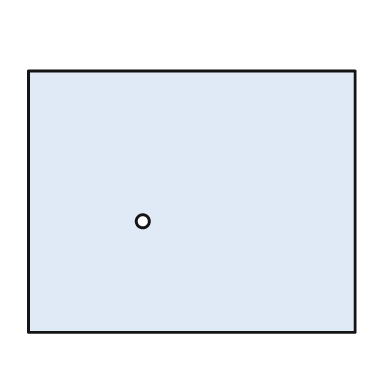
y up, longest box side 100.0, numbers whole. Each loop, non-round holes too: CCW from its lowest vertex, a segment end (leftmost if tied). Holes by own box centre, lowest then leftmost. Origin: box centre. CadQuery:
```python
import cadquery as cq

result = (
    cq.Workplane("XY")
    .moveTo(-50.0, -40.0)
    .lineTo(50.0, -40.0)
    .lineTo(50.0, 40.0)
    .lineTo(-50.0, 40.0)
    .close()
    .moveTo(-15.0, -6.0)
    .circle(2.0)
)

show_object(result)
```